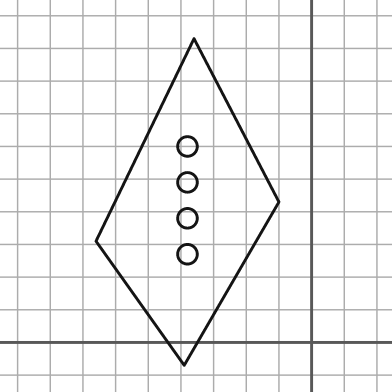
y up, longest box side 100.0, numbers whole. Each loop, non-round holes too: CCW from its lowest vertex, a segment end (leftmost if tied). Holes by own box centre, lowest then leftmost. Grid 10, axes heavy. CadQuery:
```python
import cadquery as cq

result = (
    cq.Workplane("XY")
    .moveTo(-39.0, -7.0)
    .lineTo(-10.0, 43.0)
    .lineTo(-36.0, 93.0)
    .lineTo(-66.0, 31.0)
    .close()
    .moveTo(-38.0, 27.0)
    .circle(3.0)
    .moveTo(-38.0, 38.0)
    .circle(3.0)
    .moveTo(-38.0, 49.0)
    .circle(3.0)
    .moveTo(-38.0, 60.0)
    .circle(3.0)
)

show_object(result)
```